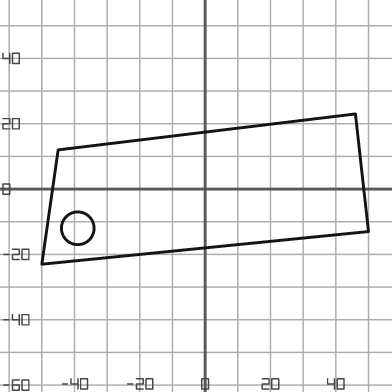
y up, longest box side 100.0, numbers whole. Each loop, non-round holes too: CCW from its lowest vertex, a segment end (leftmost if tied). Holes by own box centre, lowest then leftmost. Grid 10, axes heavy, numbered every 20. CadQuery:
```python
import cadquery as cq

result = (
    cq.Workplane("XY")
    .moveTo(-50.0, -23.0)
    .lineTo(50.0, -13.0)
    .lineTo(46.0, 23.0)
    .lineTo(-45.0, 12.0)
    .close()
    .moveTo(-39.0, -12.0)
    .circle(5.0)
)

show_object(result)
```